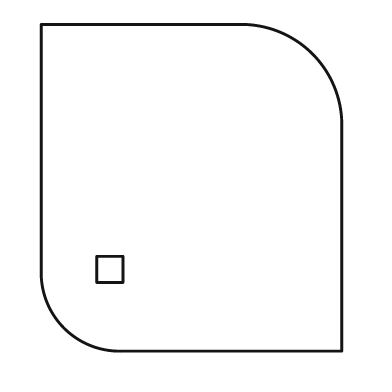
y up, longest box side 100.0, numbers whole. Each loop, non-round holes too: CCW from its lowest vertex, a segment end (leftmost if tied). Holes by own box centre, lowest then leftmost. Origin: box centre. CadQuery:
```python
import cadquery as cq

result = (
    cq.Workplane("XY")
    .moveTo(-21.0, -50.0)
    .lineTo(46.0, -50.0)
    .lineTo(46.0, 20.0)
    .threePointArc((37.0, 41.0), (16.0, 50.0))
    .lineTo(-46.0, 50.0)
    .lineTo(-46.0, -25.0)
    .threePointArc((-39.0, -43.0), (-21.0, -50.0))
    .close()
    .moveTo(-29.0, -29.0)
    .lineTo(-21.0, -29.0)
    .lineTo(-21.0, -21.0)
    .lineTo(-29.0, -21.0)
    .close()
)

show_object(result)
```